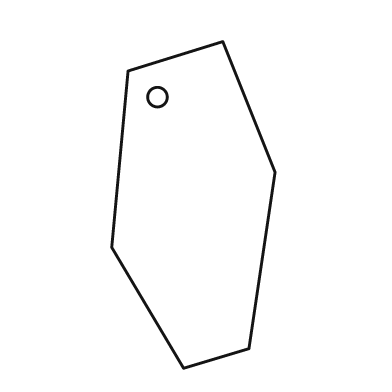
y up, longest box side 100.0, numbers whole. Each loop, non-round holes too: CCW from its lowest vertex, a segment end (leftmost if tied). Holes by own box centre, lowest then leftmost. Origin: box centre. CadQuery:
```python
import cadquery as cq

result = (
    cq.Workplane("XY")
    .moveTo(-3.0, -50.0)
    .lineTo(17.0, -44.0)
    .lineTo(25.0, 10.0)
    .lineTo(9.0, 50.0)
    .lineTo(-20.0, 41.0)
    .lineTo(-25.0, -13.0)
    .close()
    .moveTo(-11.0, 33.0)
    .circle(3.0)
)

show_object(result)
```